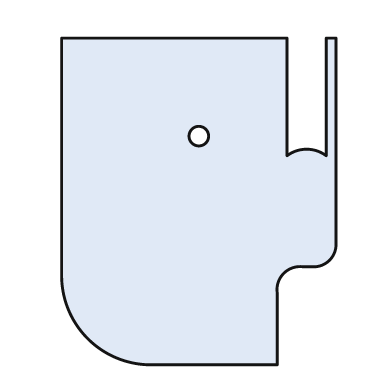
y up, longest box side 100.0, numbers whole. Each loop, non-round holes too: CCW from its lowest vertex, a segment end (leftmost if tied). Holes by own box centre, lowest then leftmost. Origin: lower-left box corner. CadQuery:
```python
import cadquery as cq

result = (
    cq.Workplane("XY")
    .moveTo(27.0, 0.0)
    .lineTo(66.0, 0.0)
    .lineTo(66.0, 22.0)
    .threePointArc((68.0, 28.0), (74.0, 30.0))
    .lineTo(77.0, 30.0)
    .threePointArc((82.0, 32.0), (84.0, 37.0))
    .lineTo(84.0, 100.0)
    .lineTo(81.0, 100.0)
    .lineTo(81.0, 64.0)
    .threePointArc((75.0, 66.0), (69.0, 64.0))
    .lineTo(69.0, 100.0)
    .lineTo(0.0, 100.0)
    .lineTo(0.0, 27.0)
    .threePointArc((8.0, 8.0), (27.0, 0.0))
    .close()
    .moveTo(42.0, 70.0)
    .circle(3.0)
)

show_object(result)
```